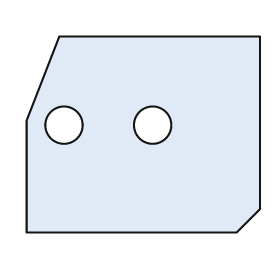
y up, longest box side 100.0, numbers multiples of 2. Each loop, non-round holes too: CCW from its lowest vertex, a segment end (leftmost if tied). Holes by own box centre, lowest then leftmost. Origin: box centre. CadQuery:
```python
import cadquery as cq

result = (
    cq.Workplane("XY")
    .moveTo(-50.0, -42.0)
    .lineTo(40.0, -42.0)
    .lineTo(50.0, -32.0)
    .lineTo(50.0, 42.0)
    .lineTo(-36.0, 42.0)
    .lineTo(-50.0, 6.0)
    .close()
    .moveTo(-34.0, 4.0)
    .circle(8.0)
    .moveTo(4.0, 4.0)
    .circle(8.0)
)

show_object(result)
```